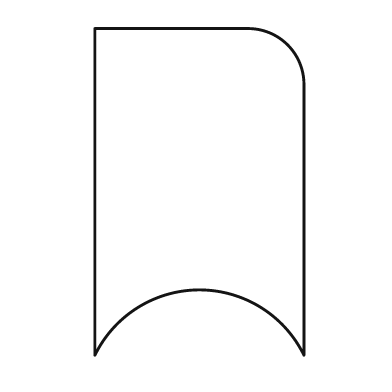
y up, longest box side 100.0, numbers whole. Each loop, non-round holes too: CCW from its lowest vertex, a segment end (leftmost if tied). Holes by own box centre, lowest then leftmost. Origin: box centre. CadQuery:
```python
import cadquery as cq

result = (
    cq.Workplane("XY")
    .moveTo(-32.0, -50.0)
    .threePointArc((0.0, -30.0), (32.0, -50.0))
    .lineTo(32.0, 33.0)
    .threePointArc((27.0, 45.0), (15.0, 50.0))
    .lineTo(-32.0, 50.0)
    .close()
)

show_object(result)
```